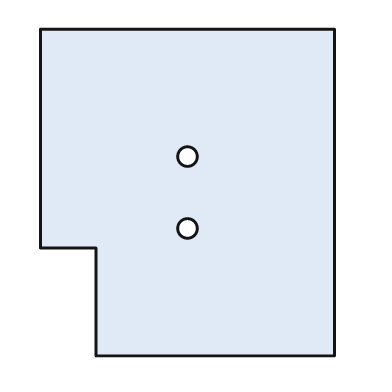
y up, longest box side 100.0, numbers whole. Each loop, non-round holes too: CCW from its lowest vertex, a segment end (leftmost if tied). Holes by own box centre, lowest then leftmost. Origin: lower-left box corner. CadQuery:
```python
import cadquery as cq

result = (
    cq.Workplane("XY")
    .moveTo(17.0, 0.0)
    .lineTo(90.0, 0.0)
    .lineTo(90.0, 100.0)
    .lineTo(0.0, 100.0)
    .lineTo(0.0, 33.0)
    .lineTo(17.0, 33.0)
    .close()
    .moveTo(45.0, 39.0)
    .circle(3.0)
    .moveTo(45.0, 61.0)
    .circle(3.0)
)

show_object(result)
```